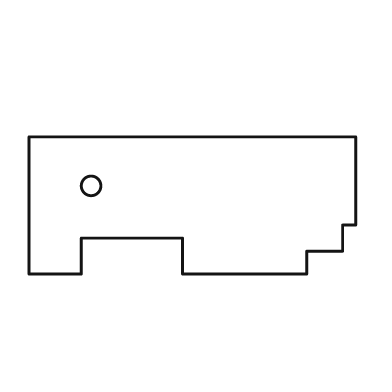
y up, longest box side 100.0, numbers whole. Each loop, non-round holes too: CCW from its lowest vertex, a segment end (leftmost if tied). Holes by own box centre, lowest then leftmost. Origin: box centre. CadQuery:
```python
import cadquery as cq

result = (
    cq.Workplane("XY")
    .moveTo(-50.0, -21.0)
    .lineTo(-34.0, -21.0)
    .lineTo(-34.0, -10.0)
    .lineTo(-3.0, -10.0)
    .lineTo(-3.0, -21.0)
    .lineTo(35.0, -21.0)
    .lineTo(35.0, -14.0)
    .lineTo(46.0, -14.0)
    .lineTo(46.0, -6.0)
    .lineTo(50.0, -6.0)
    .lineTo(50.0, 21.0)
    .lineTo(-50.0, 21.0)
    .close()
    .moveTo(-31.0, 6.0)
    .circle(3.0)
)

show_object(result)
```